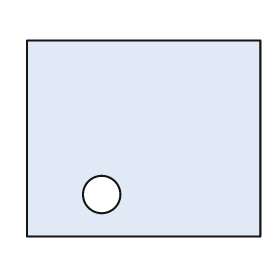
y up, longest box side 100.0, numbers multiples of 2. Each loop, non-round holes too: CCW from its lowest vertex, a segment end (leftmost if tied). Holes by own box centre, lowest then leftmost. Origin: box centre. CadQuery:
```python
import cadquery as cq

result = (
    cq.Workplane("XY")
    .moveTo(-50.0, -42.0)
    .lineTo(50.0, -42.0)
    .lineTo(50.0, 42.0)
    .lineTo(-50.0, 42.0)
    .close()
    .moveTo(-18.0, -24.0)
    .circle(8.0)
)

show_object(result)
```